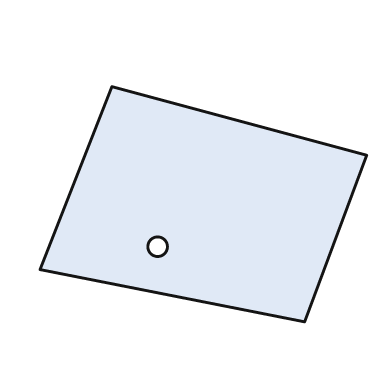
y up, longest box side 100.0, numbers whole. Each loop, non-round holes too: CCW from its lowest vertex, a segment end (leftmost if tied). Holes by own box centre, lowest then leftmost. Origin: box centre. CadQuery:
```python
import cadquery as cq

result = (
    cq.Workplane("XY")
    .moveTo(31.0, -36.0)
    .lineTo(50.0, 15.0)
    .lineTo(-28.0, 36.0)
    .lineTo(-50.0, -20.0)
    .close()
    .moveTo(-14.0, -13.0)
    .circle(3.0)
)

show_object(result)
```